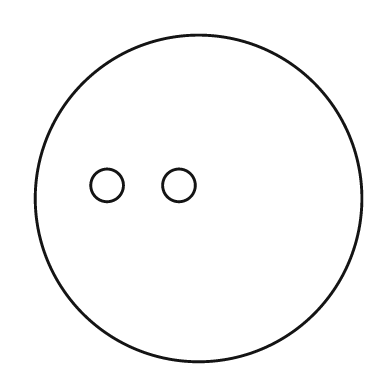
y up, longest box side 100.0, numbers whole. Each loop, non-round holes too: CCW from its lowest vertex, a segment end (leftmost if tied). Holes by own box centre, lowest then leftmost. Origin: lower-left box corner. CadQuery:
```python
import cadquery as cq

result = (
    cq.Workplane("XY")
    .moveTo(50.0, 50.0)
    .circle(50.0)
    .moveTo(22.0, 54.0)
    .circle(5.0)
    .moveTo(44.0, 54.0)
    .circle(5.0)
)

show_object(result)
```